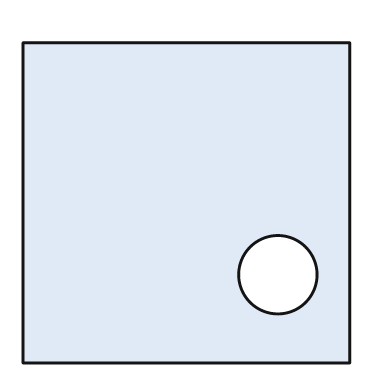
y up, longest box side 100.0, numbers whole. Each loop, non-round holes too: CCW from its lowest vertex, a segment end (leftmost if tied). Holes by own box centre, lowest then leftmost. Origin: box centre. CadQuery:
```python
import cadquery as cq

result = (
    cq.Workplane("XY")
    .moveTo(-50.0, -49.0)
    .lineTo(50.0, -49.0)
    .lineTo(50.0, 49.0)
    .lineTo(-50.0, 49.0)
    .close()
    .moveTo(28.0, -22.0)
    .circle(12.0)
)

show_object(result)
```